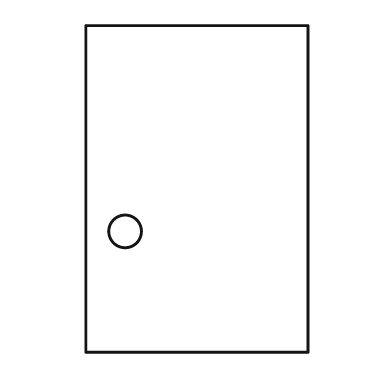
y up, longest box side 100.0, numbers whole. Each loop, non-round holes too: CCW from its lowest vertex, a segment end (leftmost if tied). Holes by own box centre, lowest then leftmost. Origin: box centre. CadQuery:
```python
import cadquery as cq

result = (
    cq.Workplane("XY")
    .moveTo(-34.0, -50.0)
    .lineTo(34.0, -50.0)
    .lineTo(34.0, 50.0)
    .lineTo(-34.0, 50.0)
    .close()
    .moveTo(-22.0, -13.0)
    .circle(5.0)
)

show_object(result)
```